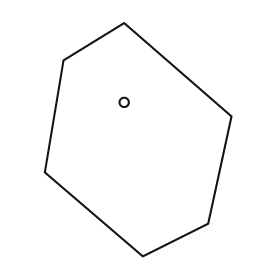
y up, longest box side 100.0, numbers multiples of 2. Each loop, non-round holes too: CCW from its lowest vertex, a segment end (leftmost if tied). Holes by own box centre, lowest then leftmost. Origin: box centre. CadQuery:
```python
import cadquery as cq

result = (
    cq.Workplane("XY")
    .moveTo(2.0, -50.0)
    .lineTo(30.0, -36.0)
    .lineTo(40.0, 10.0)
    .lineTo(-6.0, 50.0)
    .lineTo(-32.0, 34.0)
    .lineTo(-40.0, -14.0)
    .close()
    .moveTo(-6.0, 16.0)
    .circle(2.0)
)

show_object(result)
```